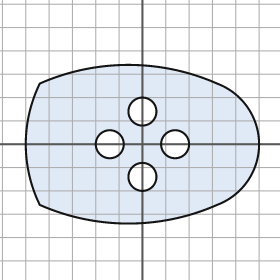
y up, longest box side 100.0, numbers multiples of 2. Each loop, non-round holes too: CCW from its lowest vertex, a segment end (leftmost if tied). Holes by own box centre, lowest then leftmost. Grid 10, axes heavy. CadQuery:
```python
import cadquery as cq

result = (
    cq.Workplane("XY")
    .moveTo(-44.0, -26.0)
    .threePointArc((-6.0, -34.0), (32.0, -26.0))
    .threePointArc((50.0, 0.0), (32.0, 26.0))
    .threePointArc((-6.0, 34.0), (-44.0, 26.0))
    .threePointArc((-50.0, 0.0), (-44.0, -26.0))
    .close()
    .moveTo(0.0, -14.0)
    .circle(6.0)
    .moveTo(-14.0, 0.0)
    .circle(6.0)
    .moveTo(14.0, 0.0)
    .circle(6.0)
    .moveTo(0.0, 14.0)
    .circle(6.0)
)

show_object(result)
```